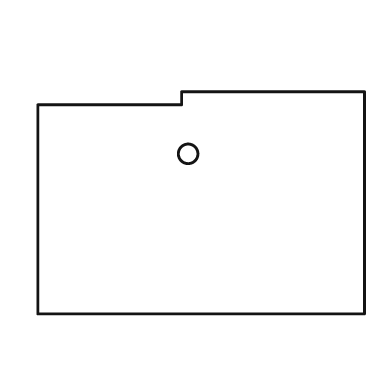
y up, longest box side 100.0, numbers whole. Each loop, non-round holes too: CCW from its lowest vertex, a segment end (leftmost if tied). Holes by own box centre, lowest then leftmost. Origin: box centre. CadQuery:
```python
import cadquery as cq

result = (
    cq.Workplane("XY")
    .moveTo(-50.0, -34.0)
    .lineTo(50.0, -34.0)
    .lineTo(50.0, 34.0)
    .lineTo(-6.0, 34.0)
    .lineTo(-6.0, 30.0)
    .lineTo(-50.0, 30.0)
    .close()
    .moveTo(-4.0, 15.0)
    .circle(3.0)
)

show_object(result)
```